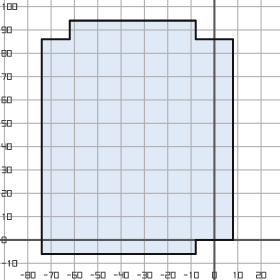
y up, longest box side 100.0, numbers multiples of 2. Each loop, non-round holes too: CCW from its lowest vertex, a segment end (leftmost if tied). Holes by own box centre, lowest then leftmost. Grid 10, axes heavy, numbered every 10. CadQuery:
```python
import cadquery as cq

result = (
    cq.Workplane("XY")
    .moveTo(-74.0, -6.0)
    .lineTo(-8.0, -6.0)
    .lineTo(-8.0, 0.0)
    .lineTo(8.0, 0.0)
    .lineTo(8.0, 86.0)
    .lineTo(-8.0, 86.0)
    .lineTo(-8.0, 94.0)
    .lineTo(-62.0, 94.0)
    .lineTo(-62.0, 86.0)
    .lineTo(-74.0, 86.0)
    .close()
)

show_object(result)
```